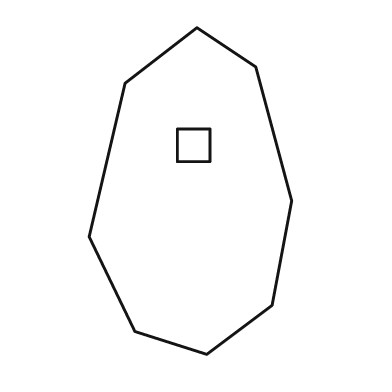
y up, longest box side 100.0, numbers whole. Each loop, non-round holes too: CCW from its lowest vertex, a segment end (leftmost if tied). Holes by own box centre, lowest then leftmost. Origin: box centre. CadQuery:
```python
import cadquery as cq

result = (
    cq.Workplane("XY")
    .moveTo(5.0, -50.0)
    .lineTo(25.0, -35.0)
    .lineTo(31.0, -3.0)
    .lineTo(20.0, 38.0)
    .lineTo(2.0, 50.0)
    .lineTo(-20.0, 33.0)
    .lineTo(-31.0, -14.0)
    .lineTo(-17.0, -43.0)
    .close()
    .moveTo(-4.0, 9.0)
    .lineTo(6.0, 9.0)
    .lineTo(6.0, 19.0)
    .lineTo(-4.0, 19.0)
    .close()
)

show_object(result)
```